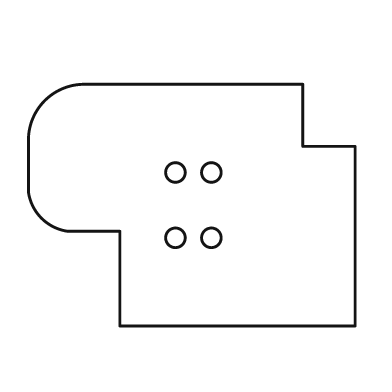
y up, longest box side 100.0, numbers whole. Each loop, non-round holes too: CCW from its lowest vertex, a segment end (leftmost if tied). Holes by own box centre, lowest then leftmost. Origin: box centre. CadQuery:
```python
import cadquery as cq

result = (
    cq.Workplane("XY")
    .moveTo(-22.0, -37.0)
    .lineTo(50.0, -37.0)
    .lineTo(50.0, 18.0)
    .lineTo(34.0, 18.0)
    .lineTo(34.0, 37.0)
    .lineTo(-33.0, 37.0)
    .threePointArc((-45.0, 32.0), (-50.0, 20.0))
    .lineTo(-50.0, 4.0)
    .threePointArc((-46.0, -4.0), (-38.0, -8.0))
    .lineTo(-22.0, -8.0)
    .close()
    .moveTo(-5.0, -10.0)
    .circle(3.0)
    .moveTo(6.0, -10.0)
    .circle(3.0)
    .moveTo(-5.0, 10.0)
    .circle(3.0)
    .moveTo(6.0, 10.0)
    .circle(3.0)
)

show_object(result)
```